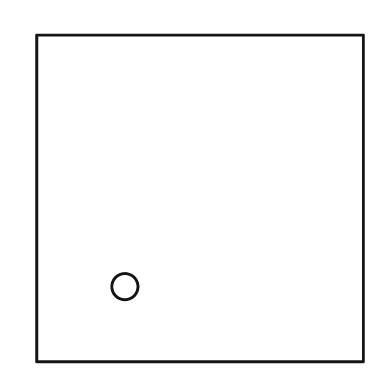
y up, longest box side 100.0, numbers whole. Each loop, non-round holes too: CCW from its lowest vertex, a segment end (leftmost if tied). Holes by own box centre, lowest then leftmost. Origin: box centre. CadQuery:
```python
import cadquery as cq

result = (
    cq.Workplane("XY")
    .moveTo(-50.0, -50.0)
    .lineTo(50.0, -50.0)
    .lineTo(50.0, 50.0)
    .lineTo(-50.0, 50.0)
    .close()
    .moveTo(-23.0, -27.0)
    .circle(4.0)
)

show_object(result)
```